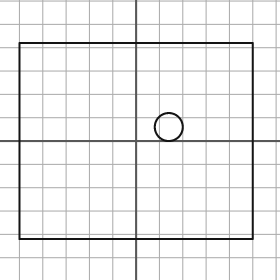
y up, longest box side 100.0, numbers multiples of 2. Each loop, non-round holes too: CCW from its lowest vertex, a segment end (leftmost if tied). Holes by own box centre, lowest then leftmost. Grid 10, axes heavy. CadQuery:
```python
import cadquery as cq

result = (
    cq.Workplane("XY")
    .moveTo(-50.0, -42.0)
    .lineTo(50.0, -42.0)
    .lineTo(50.0, 42.0)
    .lineTo(-50.0, 42.0)
    .close()
    .moveTo(14.0, 6.0)
    .circle(6.0)
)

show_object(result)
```